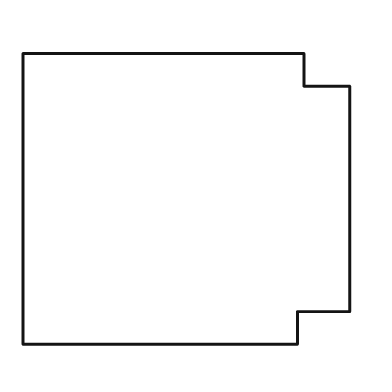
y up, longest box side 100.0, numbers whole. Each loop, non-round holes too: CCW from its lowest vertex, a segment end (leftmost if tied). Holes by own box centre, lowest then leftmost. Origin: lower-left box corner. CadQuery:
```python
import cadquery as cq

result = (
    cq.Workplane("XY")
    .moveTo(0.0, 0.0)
    .lineTo(84.0, 0.0)
    .lineTo(84.0, 10.0)
    .lineTo(100.0, 10.0)
    .lineTo(100.0, 79.0)
    .lineTo(86.0, 79.0)
    .lineTo(86.0, 89.0)
    .lineTo(0.0, 89.0)
    .close()
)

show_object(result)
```